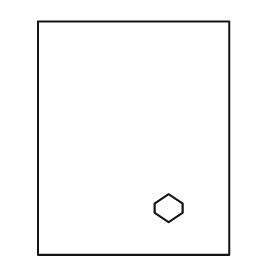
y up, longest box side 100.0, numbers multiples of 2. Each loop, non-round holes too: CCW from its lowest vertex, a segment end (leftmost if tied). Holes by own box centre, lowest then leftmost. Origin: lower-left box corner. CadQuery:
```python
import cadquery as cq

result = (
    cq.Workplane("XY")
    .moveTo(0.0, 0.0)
    .lineTo(82.0, 0.0)
    .lineTo(82.0, 100.0)
    .lineTo(0.0, 100.0)
    .close()
    .moveTo(56.0, 14.0)
    .lineTo(62.0, 18.0)
    .lineTo(62.0, 22.0)
    .lineTo(56.0, 26.0)
    .lineTo(50.0, 22.0)
    .lineTo(50.0, 18.0)
    .close()
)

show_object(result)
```